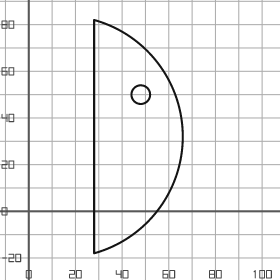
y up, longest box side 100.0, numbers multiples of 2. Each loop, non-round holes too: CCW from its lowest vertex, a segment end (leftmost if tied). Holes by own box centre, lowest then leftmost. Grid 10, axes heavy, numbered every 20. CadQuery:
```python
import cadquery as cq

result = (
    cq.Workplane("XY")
    .moveTo(28.0, -18.0)
    .threePointArc((66.0, 32.0), (28.0, 82.0))
    .close()
    .moveTo(48.0, 50.0)
    .circle(4.0)
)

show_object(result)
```